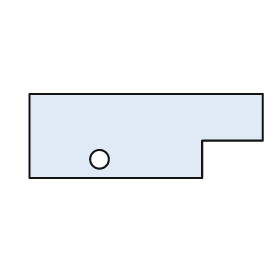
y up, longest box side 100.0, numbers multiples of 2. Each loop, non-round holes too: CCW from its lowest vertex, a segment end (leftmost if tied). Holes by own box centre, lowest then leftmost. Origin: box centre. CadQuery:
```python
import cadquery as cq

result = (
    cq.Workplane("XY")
    .moveTo(-50.0, -18.0)
    .lineTo(24.0, -18.0)
    .lineTo(24.0, -2.0)
    .lineTo(50.0, -2.0)
    .lineTo(50.0, 18.0)
    .lineTo(-50.0, 18.0)
    .close()
    .moveTo(-20.0, -10.0)
    .circle(4.0)
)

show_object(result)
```